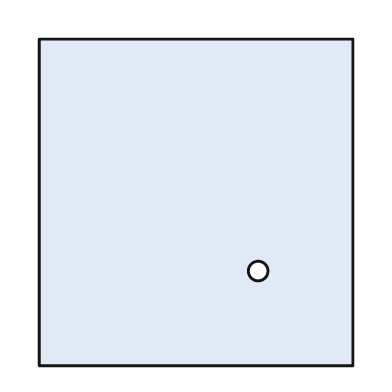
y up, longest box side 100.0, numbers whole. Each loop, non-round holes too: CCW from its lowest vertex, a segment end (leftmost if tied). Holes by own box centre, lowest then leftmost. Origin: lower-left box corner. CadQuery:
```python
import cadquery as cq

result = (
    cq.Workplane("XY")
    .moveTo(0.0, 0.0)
    .lineTo(96.0, 0.0)
    .lineTo(96.0, 100.0)
    .lineTo(0.0, 100.0)
    .close()
    .moveTo(67.0, 29.0)
    .circle(3.0)
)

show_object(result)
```